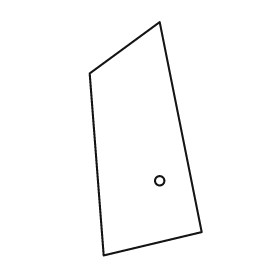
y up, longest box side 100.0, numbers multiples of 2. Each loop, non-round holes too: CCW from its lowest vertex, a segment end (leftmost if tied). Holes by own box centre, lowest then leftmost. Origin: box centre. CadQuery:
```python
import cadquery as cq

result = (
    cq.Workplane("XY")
    .moveTo(-18.0, -50.0)
    .lineTo(24.0, -40.0)
    .lineTo(6.0, 50.0)
    .lineTo(-24.0, 28.0)
    .close()
    .moveTo(6.0, -18.0)
    .circle(2.0)
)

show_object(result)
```